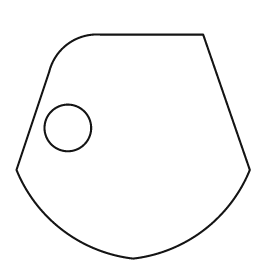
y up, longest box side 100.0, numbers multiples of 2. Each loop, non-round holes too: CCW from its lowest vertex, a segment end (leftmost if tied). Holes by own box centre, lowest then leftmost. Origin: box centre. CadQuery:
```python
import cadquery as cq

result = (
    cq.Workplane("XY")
    .moveTo(0.0, -48.0)
    .threePointArc((30.0, -36.0), (50.0, -10.0))
    .lineTo(30.0, 48.0)
    .lineTo(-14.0, 48.0)
    .threePointArc((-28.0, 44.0), (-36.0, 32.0))
    .lineTo(-50.0, -10.0)
    .threePointArc((-30.0, -36.0), (0.0, -48.0))
    .close()
    .moveTo(-28.0, 8.0)
    .circle(10.0)
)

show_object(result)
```